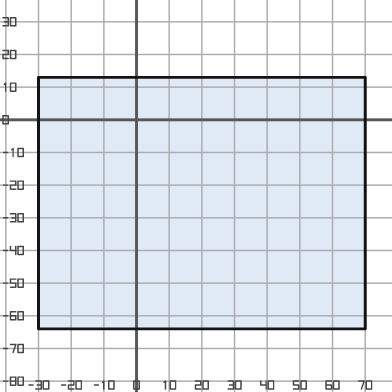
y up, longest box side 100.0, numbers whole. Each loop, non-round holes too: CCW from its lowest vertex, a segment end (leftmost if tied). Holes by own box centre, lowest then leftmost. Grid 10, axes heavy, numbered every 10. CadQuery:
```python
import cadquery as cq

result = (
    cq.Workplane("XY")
    .moveTo(-30.0, -64.0)
    .lineTo(70.0, -64.0)
    .lineTo(70.0, 13.0)
    .lineTo(-30.0, 13.0)
    .close()
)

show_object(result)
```